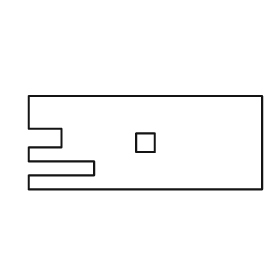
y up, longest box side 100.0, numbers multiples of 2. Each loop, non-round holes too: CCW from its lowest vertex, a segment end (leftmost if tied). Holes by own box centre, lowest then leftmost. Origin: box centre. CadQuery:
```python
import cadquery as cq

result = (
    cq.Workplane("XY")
    .moveTo(-50.0, -20.0)
    .lineTo(50.0, -20.0)
    .lineTo(50.0, 20.0)
    .lineTo(-50.0, 20.0)
    .lineTo(-50.0, 6.0)
    .lineTo(-36.0, 6.0)
    .lineTo(-36.0, -2.0)
    .lineTo(-50.0, -2.0)
    .lineTo(-50.0, -8.0)
    .lineTo(-22.0, -8.0)
    .lineTo(-22.0, -14.0)
    .lineTo(-50.0, -14.0)
    .close()
    .moveTo(-4.0, -4.0)
    .lineTo(4.0, -4.0)
    .lineTo(4.0, 4.0)
    .lineTo(-4.0, 4.0)
    .close()
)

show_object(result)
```